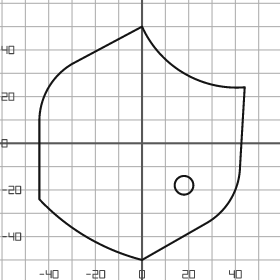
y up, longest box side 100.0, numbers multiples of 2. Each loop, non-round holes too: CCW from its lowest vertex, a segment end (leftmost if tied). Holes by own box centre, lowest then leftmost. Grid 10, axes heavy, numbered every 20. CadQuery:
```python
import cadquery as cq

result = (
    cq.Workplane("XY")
    .moveTo(0.0, -50.0)
    .lineTo(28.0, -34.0)
    .threePointArc((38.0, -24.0), (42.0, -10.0))
    .lineTo(44.0, 24.0)
    .threePointArc((18.0, 30.0), (0.0, 50.0))
    .lineTo(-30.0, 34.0)
    .threePointArc((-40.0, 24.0), (-44.0, 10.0))
    .lineTo(-44.0, -24.0)
    .threePointArc((-24.0, -40.0), (0.0, -50.0))
    .close()
    .moveTo(18.0, -18.0)
    .circle(4.0)
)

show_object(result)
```